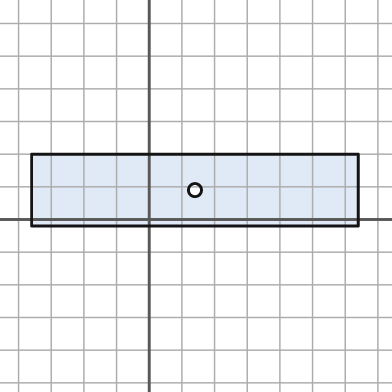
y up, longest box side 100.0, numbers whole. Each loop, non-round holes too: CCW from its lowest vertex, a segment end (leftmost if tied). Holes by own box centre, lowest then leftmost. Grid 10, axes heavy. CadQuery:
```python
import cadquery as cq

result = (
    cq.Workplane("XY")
    .moveTo(-36.0, -2.0)
    .lineTo(64.0, -2.0)
    .lineTo(64.0, 20.0)
    .lineTo(-36.0, 20.0)
    .close()
    .moveTo(14.0, 9.0)
    .circle(2.0)
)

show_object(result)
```